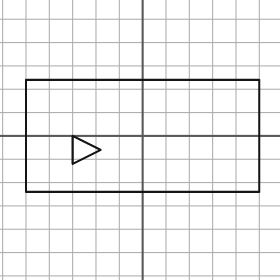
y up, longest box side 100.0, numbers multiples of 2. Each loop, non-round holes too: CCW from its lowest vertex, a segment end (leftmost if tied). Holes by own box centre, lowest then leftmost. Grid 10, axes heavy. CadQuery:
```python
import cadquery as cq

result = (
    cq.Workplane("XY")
    .moveTo(-50.0, -24.0)
    .lineTo(50.0, -24.0)
    .lineTo(50.0, 24.0)
    .lineTo(-50.0, 24.0)
    .close()
    .moveTo(-30.0, -12.0)
    .lineTo(-18.0, -6.0)
    .lineTo(-30.0, 0.0)
    .close()
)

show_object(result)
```